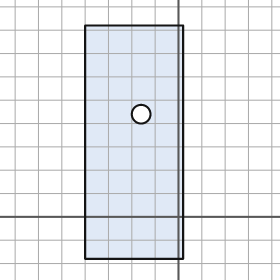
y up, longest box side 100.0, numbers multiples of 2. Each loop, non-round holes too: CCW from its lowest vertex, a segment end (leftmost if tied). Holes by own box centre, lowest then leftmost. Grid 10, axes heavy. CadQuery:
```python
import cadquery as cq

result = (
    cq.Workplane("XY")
    .moveTo(-40.0, -18.0)
    .lineTo(2.0, -18.0)
    .lineTo(2.0, 82.0)
    .lineTo(-40.0, 82.0)
    .close()
    .moveTo(-16.0, 44.0)
    .circle(4.0)
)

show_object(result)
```